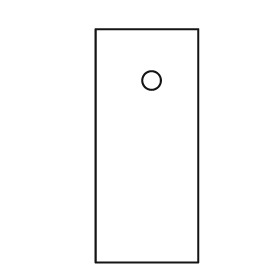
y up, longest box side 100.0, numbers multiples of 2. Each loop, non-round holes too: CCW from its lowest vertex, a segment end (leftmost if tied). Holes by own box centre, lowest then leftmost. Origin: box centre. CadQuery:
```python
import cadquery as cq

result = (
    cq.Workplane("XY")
    .moveTo(-22.0, -50.0)
    .lineTo(22.0, -50.0)
    .lineTo(22.0, 50.0)
    .lineTo(-22.0, 50.0)
    .close()
    .moveTo(2.0, 28.0)
    .circle(4.0)
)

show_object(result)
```